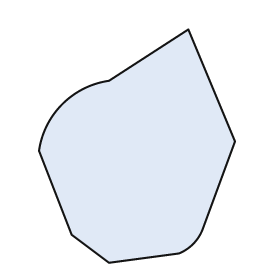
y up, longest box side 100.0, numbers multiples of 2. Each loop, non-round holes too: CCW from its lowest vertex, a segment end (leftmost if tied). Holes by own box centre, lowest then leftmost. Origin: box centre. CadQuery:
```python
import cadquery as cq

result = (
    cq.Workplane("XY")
    .moveTo(-12.0, -50.0)
    .lineTo(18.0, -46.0)
    .threePointArc((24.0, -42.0), (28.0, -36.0))
    .lineTo(42.0, 2.0)
    .lineTo(22.0, 50.0)
    .lineTo(-12.0, 28.0)
    .threePointArc((-32.0, 18.0), (-42.0, -2.0))
    .lineTo(-28.0, -38.0)
    .close()
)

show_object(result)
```